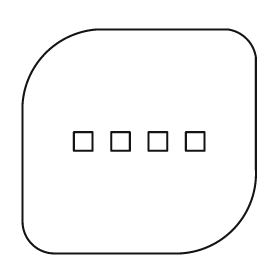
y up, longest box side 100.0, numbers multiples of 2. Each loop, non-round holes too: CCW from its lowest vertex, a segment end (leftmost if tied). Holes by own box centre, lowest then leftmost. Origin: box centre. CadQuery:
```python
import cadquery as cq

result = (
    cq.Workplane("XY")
    .moveTo(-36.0, -48.0)
    .lineTo(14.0, -48.0)
    .threePointArc((40.0, -38.0), (50.0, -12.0))
    .lineTo(50.0, 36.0)
    .threePointArc((46.0, 44.0), (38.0, 48.0))
    .lineTo(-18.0, 48.0)
    .threePointArc((-40.0, 38.0), (-50.0, 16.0))
    .lineTo(-50.0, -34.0)
    .threePointArc((-46.0, -44.0), (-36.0, -48.0))
    .close()
    .moveTo(-28.0, -4.0)
    .lineTo(-20.0, -4.0)
    .lineTo(-20.0, 4.0)
    .lineTo(-28.0, 4.0)
    .close()
    .moveTo(-12.0, -4.0)
    .lineTo(-4.0, -4.0)
    .lineTo(-4.0, 4.0)
    .lineTo(-12.0, 4.0)
    .close()
    .moveTo(4.0, -4.0)
    .lineTo(12.0, -4.0)
    .lineTo(12.0, 4.0)
    .lineTo(4.0, 4.0)
    .close()
    .moveTo(20.0, -4.0)
    .lineTo(28.0, -4.0)
    .lineTo(28.0, 4.0)
    .lineTo(20.0, 4.0)
    .close()
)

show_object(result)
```